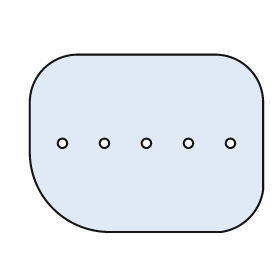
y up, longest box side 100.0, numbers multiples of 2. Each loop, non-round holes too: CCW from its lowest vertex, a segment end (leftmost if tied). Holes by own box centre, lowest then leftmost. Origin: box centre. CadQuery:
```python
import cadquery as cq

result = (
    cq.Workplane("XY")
    .moveTo(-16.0, -38.0)
    .lineTo(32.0, -38.0)
    .threePointArc((44.0, -32.0), (50.0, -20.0))
    .lineTo(50.0, 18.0)
    .threePointArc((44.0, 32.0), (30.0, 38.0))
    .lineTo(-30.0, 38.0)
    .threePointArc((-44.0, 32.0), (-50.0, 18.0))
    .lineTo(-50.0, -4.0)
    .threePointArc((-40.0, -28.0), (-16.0, -38.0))
    .close()
    .moveTo(-36.0, 0.0)
    .circle(2.0)
    .moveTo(-18.0, 0.0)
    .circle(2.0)
    .moveTo(0.0, 0.0)
    .circle(2.0)
    .moveTo(18.0, 0.0)
    .circle(2.0)
    .moveTo(36.0, 0.0)
    .circle(2.0)
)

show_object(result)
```